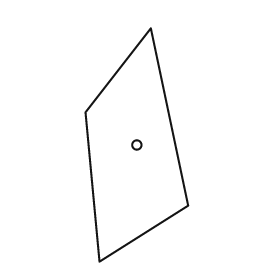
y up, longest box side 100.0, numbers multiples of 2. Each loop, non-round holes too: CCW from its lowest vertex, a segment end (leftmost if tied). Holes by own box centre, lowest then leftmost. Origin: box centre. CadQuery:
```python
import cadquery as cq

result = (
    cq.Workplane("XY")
    .moveTo(-16.0, -50.0)
    .lineTo(22.0, -26.0)
    .lineTo(6.0, 50.0)
    .lineTo(-22.0, 14.0)
    .close()
    .moveTo(0.0, 0.0)
    .circle(2.0)
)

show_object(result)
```